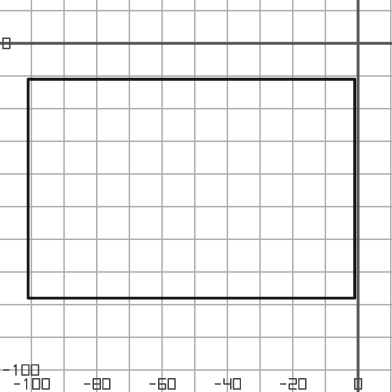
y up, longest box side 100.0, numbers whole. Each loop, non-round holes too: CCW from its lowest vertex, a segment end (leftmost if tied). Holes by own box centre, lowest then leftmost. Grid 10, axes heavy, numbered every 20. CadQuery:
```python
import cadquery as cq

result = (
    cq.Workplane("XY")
    .moveTo(-101.0, -78.0)
    .lineTo(-1.0, -78.0)
    .lineTo(-1.0, -11.0)
    .lineTo(-101.0, -11.0)
    .close()
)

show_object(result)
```